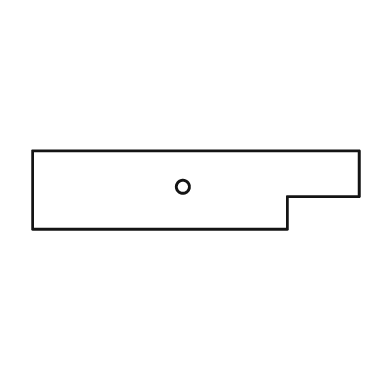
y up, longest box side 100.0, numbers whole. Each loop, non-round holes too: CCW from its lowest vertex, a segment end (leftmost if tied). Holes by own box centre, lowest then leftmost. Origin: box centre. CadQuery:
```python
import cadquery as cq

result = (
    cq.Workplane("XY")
    .moveTo(-50.0, -12.0)
    .lineTo(28.0, -12.0)
    .lineTo(28.0, -2.0)
    .lineTo(50.0, -2.0)
    .lineTo(50.0, 12.0)
    .lineTo(-50.0, 12.0)
    .close()
    .moveTo(-4.0, 1.0)
    .circle(2.0)
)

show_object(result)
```